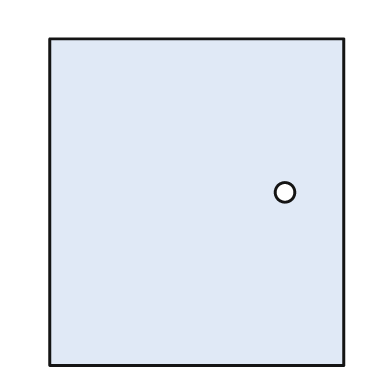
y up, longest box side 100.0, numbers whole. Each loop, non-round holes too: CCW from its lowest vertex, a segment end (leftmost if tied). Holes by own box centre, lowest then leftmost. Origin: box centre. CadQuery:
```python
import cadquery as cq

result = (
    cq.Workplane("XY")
    .moveTo(-45.0, -50.0)
    .lineTo(45.0, -50.0)
    .lineTo(45.0, 50.0)
    .lineTo(-45.0, 50.0)
    .close()
    .moveTo(27.0, 3.0)
    .circle(3.0)
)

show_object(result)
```